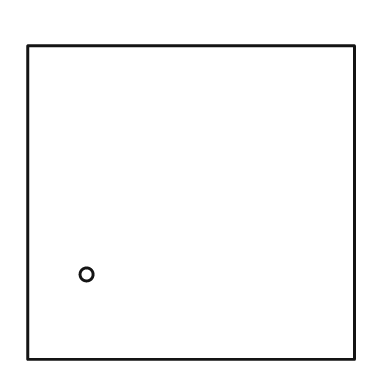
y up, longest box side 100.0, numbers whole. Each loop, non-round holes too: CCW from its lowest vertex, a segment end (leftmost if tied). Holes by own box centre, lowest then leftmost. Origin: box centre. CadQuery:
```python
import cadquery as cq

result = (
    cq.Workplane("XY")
    .moveTo(-50.0, -48.0)
    .lineTo(50.0, -48.0)
    .lineTo(50.0, 48.0)
    .lineTo(-50.0, 48.0)
    .close()
    .moveTo(-32.0, -22.0)
    .circle(2.0)
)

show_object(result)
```